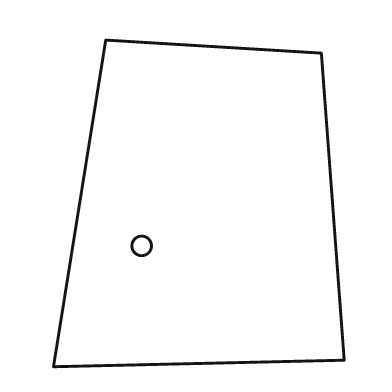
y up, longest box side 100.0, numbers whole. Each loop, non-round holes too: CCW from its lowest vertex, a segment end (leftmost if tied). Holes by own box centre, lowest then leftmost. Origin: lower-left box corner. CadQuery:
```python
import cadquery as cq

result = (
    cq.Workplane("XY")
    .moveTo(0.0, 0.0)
    .lineTo(89.0, 2.0)
    .lineTo(82.0, 96.0)
    .lineTo(16.0, 100.0)
    .close()
    .moveTo(27.0, 37.0)
    .circle(3.0)
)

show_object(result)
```